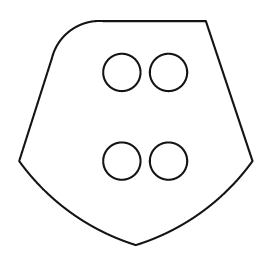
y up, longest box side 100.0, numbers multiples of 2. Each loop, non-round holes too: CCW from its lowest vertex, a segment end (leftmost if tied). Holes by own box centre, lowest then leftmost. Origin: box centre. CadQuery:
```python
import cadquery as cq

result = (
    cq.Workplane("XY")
    .moveTo(0.0, -48.0)
    .threePointArc((28.0, -34.0), (50.0, -12.0))
    .lineTo(30.0, 48.0)
    .lineTo(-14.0, 48.0)
    .threePointArc((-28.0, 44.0), (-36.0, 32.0))
    .lineTo(-50.0, -12.0)
    .threePointArc((-28.0, -34.0), (0.0, -48.0))
    .close()
    .moveTo(-6.0, -12.0)
    .circle(8.0)
    .moveTo(14.0, -12.0)
    .circle(8.0)
    .moveTo(-6.0, 26.0)
    .circle(8.0)
    .moveTo(14.0, 26.0)
    .circle(8.0)
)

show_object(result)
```